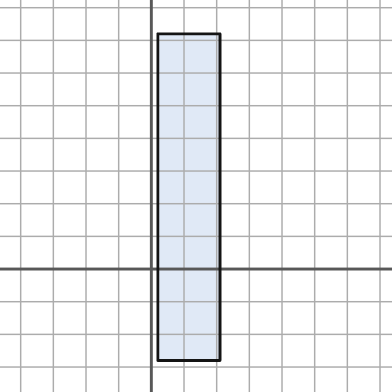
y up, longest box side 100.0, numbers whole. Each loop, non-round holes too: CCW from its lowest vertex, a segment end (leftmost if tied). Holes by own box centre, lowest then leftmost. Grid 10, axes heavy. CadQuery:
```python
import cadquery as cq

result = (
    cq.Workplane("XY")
    .moveTo(2.0, -28.0)
    .lineTo(21.0, -28.0)
    .lineTo(21.0, 72.0)
    .lineTo(2.0, 72.0)
    .close()
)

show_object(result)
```